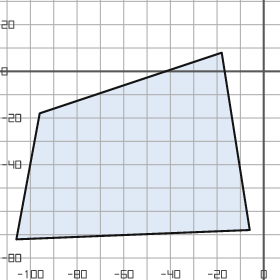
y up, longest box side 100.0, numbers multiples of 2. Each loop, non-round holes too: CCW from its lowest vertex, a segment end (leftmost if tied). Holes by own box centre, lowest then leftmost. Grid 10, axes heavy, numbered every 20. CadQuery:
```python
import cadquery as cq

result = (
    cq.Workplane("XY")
    .moveTo(-106.0, -72.0)
    .lineTo(-6.0, -68.0)
    .lineTo(-18.0, 8.0)
    .lineTo(-96.0, -18.0)
    .close()
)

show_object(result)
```